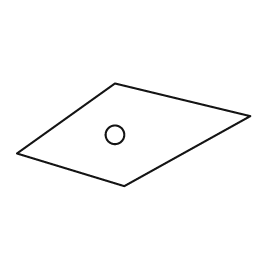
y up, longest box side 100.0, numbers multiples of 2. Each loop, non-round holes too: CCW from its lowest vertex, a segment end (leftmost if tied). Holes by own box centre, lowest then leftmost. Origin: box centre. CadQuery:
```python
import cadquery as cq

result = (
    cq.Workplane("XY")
    .moveTo(-4.0, -22.0)
    .lineTo(50.0, 8.0)
    .lineTo(-8.0, 22.0)
    .lineTo(-50.0, -8.0)
    .close()
    .moveTo(-8.0, 0.0)
    .circle(4.0)
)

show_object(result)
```